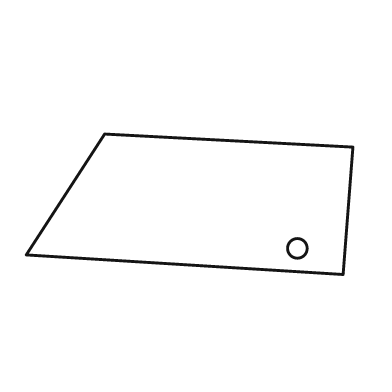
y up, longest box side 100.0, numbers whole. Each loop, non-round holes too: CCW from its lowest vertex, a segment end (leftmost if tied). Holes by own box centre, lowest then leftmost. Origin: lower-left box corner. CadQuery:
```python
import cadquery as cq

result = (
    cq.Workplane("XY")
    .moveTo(97.0, 0.0)
    .lineTo(100.0, 39.0)
    .lineTo(24.0, 43.0)
    .lineTo(0.0, 6.0)
    .close()
    .moveTo(83.0, 8.0)
    .circle(3.0)
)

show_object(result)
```